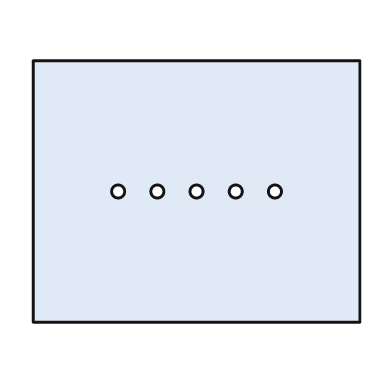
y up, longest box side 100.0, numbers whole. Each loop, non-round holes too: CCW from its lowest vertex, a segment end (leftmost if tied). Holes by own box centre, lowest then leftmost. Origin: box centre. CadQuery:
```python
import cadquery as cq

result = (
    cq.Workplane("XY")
    .moveTo(-50.0, -40.0)
    .lineTo(50.0, -40.0)
    .lineTo(50.0, 40.0)
    .lineTo(-50.0, 40.0)
    .close()
    .moveTo(-24.0, 0.0)
    .circle(2.0)
    .moveTo(-12.0, 0.0)
    .circle(2.0)
    .moveTo(0.0, 0.0)
    .circle(2.0)
    .moveTo(12.0, 0.0)
    .circle(2.0)
    .moveTo(24.0, 0.0)
    .circle(2.0)
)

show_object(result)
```